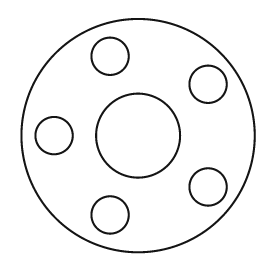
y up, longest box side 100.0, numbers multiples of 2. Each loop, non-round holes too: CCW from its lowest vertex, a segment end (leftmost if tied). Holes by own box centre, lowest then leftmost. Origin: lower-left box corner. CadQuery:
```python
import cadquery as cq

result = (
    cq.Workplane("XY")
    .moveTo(50.0, 50.0)
    .circle(50.0)
    .moveTo(38.0, 16.0)
    .circle(8.0)
    .moveTo(80.0, 28.0)
    .circle(8.0)
    .moveTo(14.0, 50.0)
    .circle(8.0)
    .moveTo(50.0, 50.0)
    .circle(18.0)
    .moveTo(80.0, 72.0)
    .circle(8.0)
    .moveTo(38.0, 84.0)
    .circle(8.0)
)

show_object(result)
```